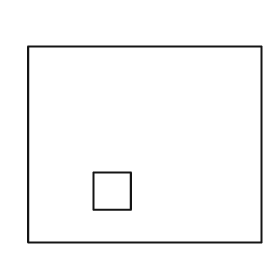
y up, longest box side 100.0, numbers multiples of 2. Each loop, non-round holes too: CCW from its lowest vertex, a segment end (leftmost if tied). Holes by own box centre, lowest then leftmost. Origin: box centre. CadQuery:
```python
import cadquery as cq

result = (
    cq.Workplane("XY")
    .moveTo(-50.0, -42.0)
    .lineTo(50.0, -42.0)
    .lineTo(50.0, 42.0)
    .lineTo(-50.0, 42.0)
    .close()
    .moveTo(-22.0, -28.0)
    .lineTo(-6.0, -28.0)
    .lineTo(-6.0, -12.0)
    .lineTo(-22.0, -12.0)
    .close()
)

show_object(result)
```